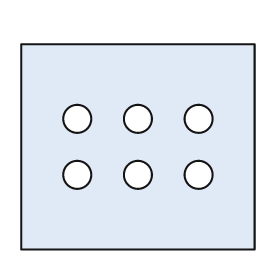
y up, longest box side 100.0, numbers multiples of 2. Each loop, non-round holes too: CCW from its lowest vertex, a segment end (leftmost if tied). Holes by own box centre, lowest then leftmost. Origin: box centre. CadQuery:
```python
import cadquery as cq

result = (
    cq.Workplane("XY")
    .moveTo(-50.0, -44.0)
    .lineTo(50.0, -44.0)
    .lineTo(50.0, 44.0)
    .lineTo(-50.0, 44.0)
    .close()
    .moveTo(-26.0, -12.0)
    .circle(6.0)
    .moveTo(0.0, -12.0)
    .circle(6.0)
    .moveTo(26.0, -12.0)
    .circle(6.0)
    .moveTo(-26.0, 12.0)
    .circle(6.0)
    .moveTo(0.0, 12.0)
    .circle(6.0)
    .moveTo(26.0, 12.0)
    .circle(6.0)
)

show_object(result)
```